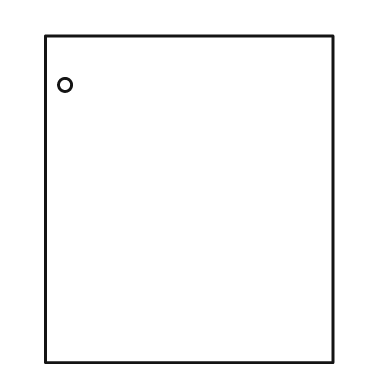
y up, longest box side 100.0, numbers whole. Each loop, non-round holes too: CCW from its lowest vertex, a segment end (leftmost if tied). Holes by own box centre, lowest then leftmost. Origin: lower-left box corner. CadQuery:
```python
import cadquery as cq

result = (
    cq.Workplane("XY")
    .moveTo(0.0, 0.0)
    .lineTo(88.0, 0.0)
    .lineTo(88.0, 100.0)
    .lineTo(0.0, 100.0)
    .close()
    .moveTo(6.0, 85.0)
    .circle(2.0)
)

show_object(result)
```